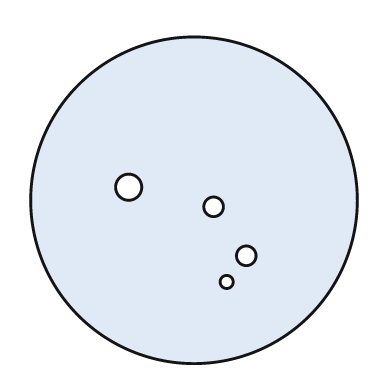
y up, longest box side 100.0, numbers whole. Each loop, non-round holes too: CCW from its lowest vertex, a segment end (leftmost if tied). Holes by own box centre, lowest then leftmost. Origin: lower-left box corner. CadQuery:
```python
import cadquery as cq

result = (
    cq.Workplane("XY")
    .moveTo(50.0, 50.0)
    .circle(50.0)
    .moveTo(60.0, 25.0)
    .circle(2.0)
    .moveTo(66.0, 33.0)
    .circle(3.0)
    .moveTo(56.0, 48.0)
    .circle(3.0)
    .moveTo(30.0, 54.0)
    .circle(4.0)
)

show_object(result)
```